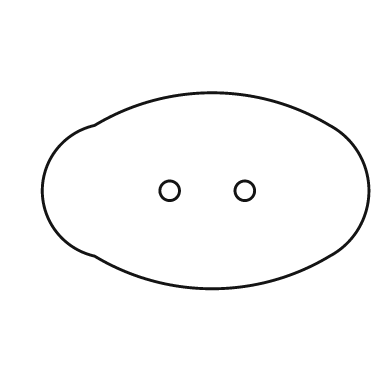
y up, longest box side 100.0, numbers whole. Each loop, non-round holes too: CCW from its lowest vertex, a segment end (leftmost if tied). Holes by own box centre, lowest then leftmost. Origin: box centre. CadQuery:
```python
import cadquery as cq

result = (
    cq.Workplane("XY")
    .moveTo(-34.0, -20.0)
    .threePointArc((2.0, -30.0), (38.0, -20.0))
    .threePointArc((50.0, 0.0), (38.0, 20.0))
    .threePointArc((2.0, 30.0), (-34.0, 20.0))
    .threePointArc((-50.0, 0.0), (-34.0, -20.0))
    .close()
    .moveTo(-11.0, 0.0)
    .circle(3.0)
    .moveTo(12.0, 0.0)
    .circle(3.0)
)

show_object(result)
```